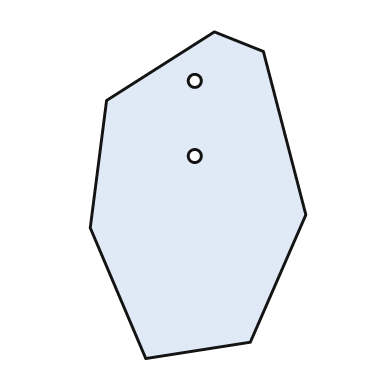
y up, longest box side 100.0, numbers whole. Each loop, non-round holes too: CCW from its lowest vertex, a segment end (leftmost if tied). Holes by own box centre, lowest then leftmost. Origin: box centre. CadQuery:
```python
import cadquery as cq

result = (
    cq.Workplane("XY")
    .moveTo(-16.0, -50.0)
    .lineTo(16.0, -45.0)
    .lineTo(33.0, -6.0)
    .lineTo(20.0, 44.0)
    .lineTo(5.0, 50.0)
    .lineTo(-28.0, 29.0)
    .lineTo(-33.0, -10.0)
    .close()
    .moveTo(-1.0, 12.0)
    .circle(2.0)
    .moveTo(-1.0, 35.0)
    .circle(2.0)
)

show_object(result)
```